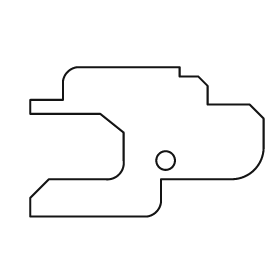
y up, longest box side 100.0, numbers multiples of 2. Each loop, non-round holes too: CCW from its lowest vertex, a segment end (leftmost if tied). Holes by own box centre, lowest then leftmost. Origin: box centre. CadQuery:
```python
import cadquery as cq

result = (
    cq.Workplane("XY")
    .moveTo(-50.0, -32.0)
    .lineTo(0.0, -32.0)
    .threePointArc((4.0, -30.0), (6.0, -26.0))
    .lineTo(6.0, -16.0)
    .lineTo(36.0, -16.0)
    .threePointArc((46.0, -12.0), (50.0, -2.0))
    .lineTo(50.0, 10.0)
    .lineTo(44.0, 16.0)
    .lineTo(26.0, 16.0)
    .lineTo(26.0, 24.0)
    .lineTo(22.0, 28.0)
    .lineTo(14.0, 28.0)
    .lineTo(14.0, 32.0)
    .lineTo(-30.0, 32.0)
    .threePointArc((-34.0, 30.0), (-36.0, 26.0))
    .lineTo(-36.0, 18.0)
    .lineTo(-50.0, 18.0)
    .lineTo(-50.0, 12.0)
    .lineTo(-20.0, 12.0)
    .lineTo(-10.0, 4.0)
    .lineTo(-10.0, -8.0)
    .threePointArc((-12.0, -14.0), (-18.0, -16.0))
    .lineTo(-42.0, -16.0)
    .lineTo(-50.0, -24.0)
    .close()
    .moveTo(8.0, -8.0)
    .circle(4.0)
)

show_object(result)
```